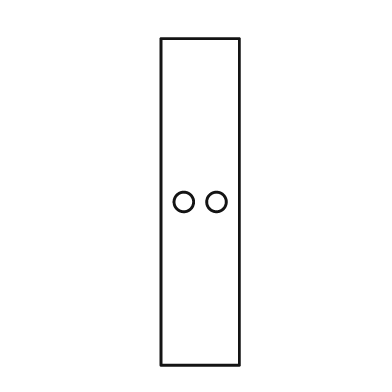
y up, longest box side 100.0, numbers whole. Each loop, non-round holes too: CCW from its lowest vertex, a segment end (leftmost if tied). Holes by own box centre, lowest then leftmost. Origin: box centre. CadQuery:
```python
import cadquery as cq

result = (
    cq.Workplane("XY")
    .moveTo(-12.0, -50.0)
    .lineTo(12.0, -50.0)
    .lineTo(12.0, 50.0)
    .lineTo(-12.0, 50.0)
    .close()
    .moveTo(-5.0, 0.0)
    .circle(3.0)
    .moveTo(5.0, 0.0)
    .circle(3.0)
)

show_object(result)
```